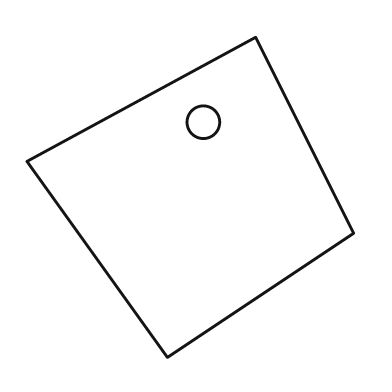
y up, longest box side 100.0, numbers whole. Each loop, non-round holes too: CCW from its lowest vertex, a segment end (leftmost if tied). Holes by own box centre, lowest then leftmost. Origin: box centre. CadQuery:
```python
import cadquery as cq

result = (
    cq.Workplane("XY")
    .moveTo(-7.0, -49.0)
    .lineTo(50.0, -11.0)
    .lineTo(20.0, 49.0)
    .lineTo(-50.0, 11.0)
    .close()
    .moveTo(4.0, 23.0)
    .circle(5.0)
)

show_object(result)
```